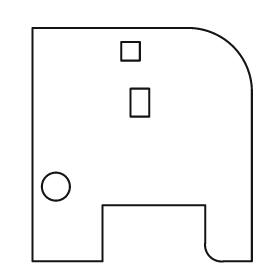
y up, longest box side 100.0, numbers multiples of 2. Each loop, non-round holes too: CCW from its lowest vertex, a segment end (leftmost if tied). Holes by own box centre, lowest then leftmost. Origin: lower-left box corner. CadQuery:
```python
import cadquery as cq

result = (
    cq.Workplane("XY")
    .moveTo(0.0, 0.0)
    .lineTo(30.0, 0.0)
    .lineTo(30.0, 24.0)
    .lineTo(74.0, 24.0)
    .lineTo(74.0, 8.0)
    .threePointArc((76.0, 2.0), (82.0, 0.0))
    .lineTo(94.0, 0.0)
    .lineTo(94.0, 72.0)
    .threePointArc((86.0, 92.0), (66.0, 100.0))
    .lineTo(0.0, 100.0)
    .close()
    .moveTo(10.0, 32.0)
    .circle(6.0)
    .moveTo(42.0, 62.0)
    .lineTo(50.0, 62.0)
    .lineTo(50.0, 74.0)
    .lineTo(42.0, 74.0)
    .close()
    .moveTo(38.0, 86.0)
    .lineTo(46.0, 86.0)
    .lineTo(46.0, 94.0)
    .lineTo(38.0, 94.0)
    .close()
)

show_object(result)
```